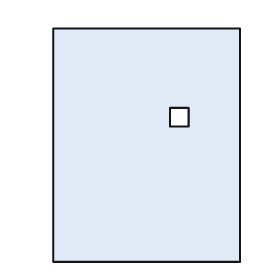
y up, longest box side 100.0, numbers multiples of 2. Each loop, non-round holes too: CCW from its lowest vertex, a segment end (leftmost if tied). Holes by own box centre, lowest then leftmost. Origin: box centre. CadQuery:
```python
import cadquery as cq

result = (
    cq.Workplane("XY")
    .moveTo(-40.0, -50.0)
    .lineTo(40.0, -50.0)
    .lineTo(40.0, 50.0)
    .lineTo(-40.0, 50.0)
    .close()
    .moveTo(10.0, 8.0)
    .lineTo(18.0, 8.0)
    .lineTo(18.0, 16.0)
    .lineTo(10.0, 16.0)
    .close()
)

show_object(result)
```